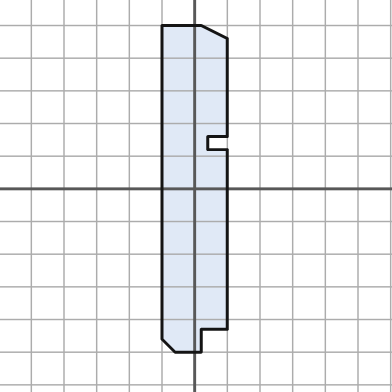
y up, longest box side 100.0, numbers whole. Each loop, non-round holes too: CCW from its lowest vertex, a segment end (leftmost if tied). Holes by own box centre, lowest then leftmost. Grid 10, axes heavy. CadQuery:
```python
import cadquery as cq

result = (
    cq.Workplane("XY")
    .moveTo(-6.0, -50.0)
    .lineTo(2.0, -50.0)
    .lineTo(2.0, -43.0)
    .lineTo(10.0, -43.0)
    .lineTo(10.0, 12.0)
    .lineTo(4.0, 12.0)
    .lineTo(4.0, 16.0)
    .lineTo(10.0, 16.0)
    .lineTo(10.0, 46.0)
    .lineTo(2.0, 50.0)
    .lineTo(-10.0, 50.0)
    .lineTo(-10.0, -46.0)
    .close()
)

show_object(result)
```